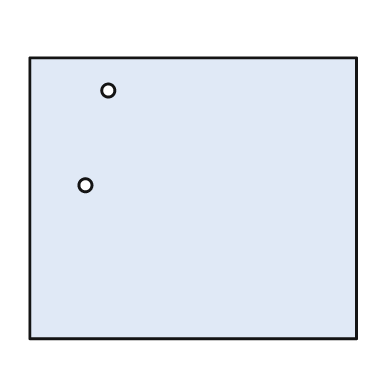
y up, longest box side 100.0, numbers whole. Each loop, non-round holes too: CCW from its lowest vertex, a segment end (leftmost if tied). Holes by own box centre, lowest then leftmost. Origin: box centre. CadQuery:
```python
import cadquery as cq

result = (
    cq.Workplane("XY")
    .moveTo(-50.0, -43.0)
    .lineTo(50.0, -43.0)
    .lineTo(50.0, 43.0)
    .lineTo(-50.0, 43.0)
    .close()
    .moveTo(-33.0, 4.0)
    .circle(2.0)
    .moveTo(-26.0, 33.0)
    .circle(2.0)
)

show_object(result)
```